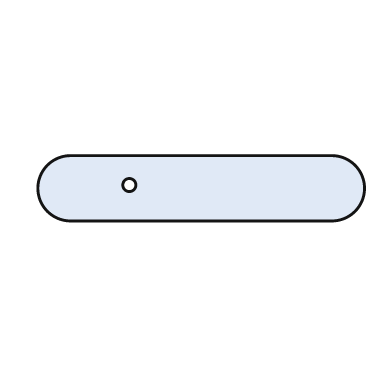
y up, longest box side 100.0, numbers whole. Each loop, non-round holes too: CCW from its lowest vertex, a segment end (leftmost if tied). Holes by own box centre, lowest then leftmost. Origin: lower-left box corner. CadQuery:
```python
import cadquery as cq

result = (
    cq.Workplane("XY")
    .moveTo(10.0, 0.0)
    .lineTo(90.0, 0.0)
    .threePointArc((100.0, 10.0), (90.0, 20.0))
    .lineTo(10.0, 20.0)
    .threePointArc((0.0, 10.0), (10.0, 0.0))
    .close()
    .moveTo(28.0, 11.0)
    .circle(2.0)
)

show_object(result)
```